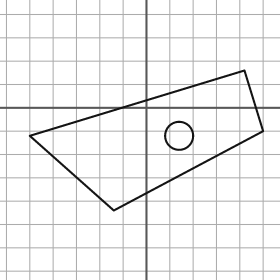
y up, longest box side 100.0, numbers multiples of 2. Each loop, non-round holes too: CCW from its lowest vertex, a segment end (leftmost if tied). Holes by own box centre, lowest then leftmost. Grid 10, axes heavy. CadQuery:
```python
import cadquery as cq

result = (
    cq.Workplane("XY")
    .moveTo(-14.0, -44.0)
    .lineTo(50.0, -10.0)
    .lineTo(42.0, 16.0)
    .lineTo(-50.0, -12.0)
    .close()
    .moveTo(14.0, -12.0)
    .circle(6.0)
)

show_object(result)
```